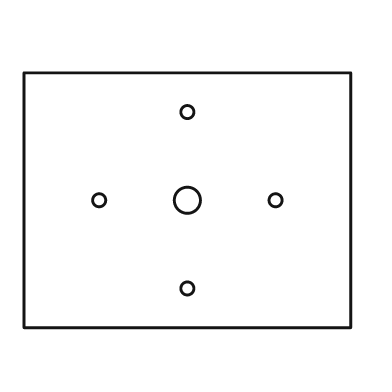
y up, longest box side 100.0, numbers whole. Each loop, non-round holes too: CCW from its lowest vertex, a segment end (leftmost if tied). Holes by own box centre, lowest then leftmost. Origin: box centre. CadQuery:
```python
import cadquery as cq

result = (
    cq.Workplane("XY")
    .moveTo(-50.0, -39.0)
    .lineTo(50.0, -39.0)
    .lineTo(50.0, 39.0)
    .lineTo(-50.0, 39.0)
    .close()
    .moveTo(0.0, -27.0)
    .circle(2.0)
    .moveTo(-27.0, 0.0)
    .circle(2.0)
    .moveTo(0.0, 0.0)
    .circle(4.0)
    .moveTo(27.0, 0.0)
    .circle(2.0)
    .moveTo(0.0, 27.0)
    .circle(2.0)
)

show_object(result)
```